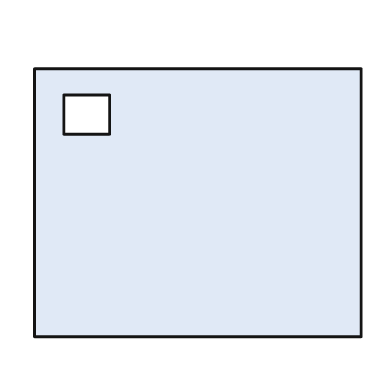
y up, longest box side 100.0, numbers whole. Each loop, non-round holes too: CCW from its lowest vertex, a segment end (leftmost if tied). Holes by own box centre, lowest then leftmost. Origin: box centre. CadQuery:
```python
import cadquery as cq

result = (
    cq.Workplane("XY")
    .moveTo(-50.0, -41.0)
    .lineTo(50.0, -41.0)
    .lineTo(50.0, 41.0)
    .lineTo(-50.0, 41.0)
    .close()
    .moveTo(-41.0, 21.0)
    .lineTo(-27.0, 21.0)
    .lineTo(-27.0, 33.0)
    .lineTo(-41.0, 33.0)
    .close()
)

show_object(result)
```